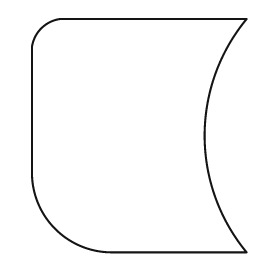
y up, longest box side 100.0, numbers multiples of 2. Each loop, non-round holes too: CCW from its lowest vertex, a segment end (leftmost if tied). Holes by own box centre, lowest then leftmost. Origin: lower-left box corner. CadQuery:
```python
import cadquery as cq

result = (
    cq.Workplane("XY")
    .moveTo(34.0, 0.0)
    .lineTo(92.0, 0.0)
    .threePointArc((74.0, 50.0), (92.0, 100.0))
    .lineTo(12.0, 100.0)
    .threePointArc((4.0, 96.0), (0.0, 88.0))
    .lineTo(0.0, 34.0)
    .threePointArc((10.0, 10.0), (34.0, 0.0))
    .close()
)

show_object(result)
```